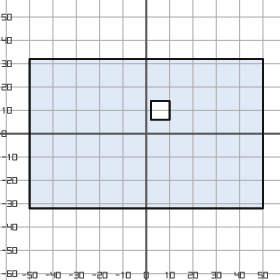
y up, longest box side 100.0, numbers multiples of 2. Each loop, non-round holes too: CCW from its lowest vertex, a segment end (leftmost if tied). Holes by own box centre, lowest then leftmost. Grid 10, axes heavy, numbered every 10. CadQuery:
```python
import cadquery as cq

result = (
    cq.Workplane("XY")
    .moveTo(-50.0, -32.0)
    .lineTo(50.0, -32.0)
    .lineTo(50.0, 32.0)
    .lineTo(-50.0, 32.0)
    .close()
    .moveTo(2.0, 6.0)
    .lineTo(10.0, 6.0)
    .lineTo(10.0, 14.0)
    .lineTo(2.0, 14.0)
    .close()
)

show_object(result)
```